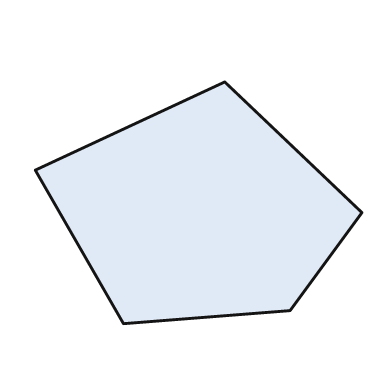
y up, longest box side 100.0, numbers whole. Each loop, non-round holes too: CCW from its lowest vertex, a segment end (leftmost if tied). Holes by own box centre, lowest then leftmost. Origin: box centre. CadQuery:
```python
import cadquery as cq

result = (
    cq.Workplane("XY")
    .moveTo(-23.0, -37.0)
    .lineTo(28.0, -33.0)
    .lineTo(50.0, -3.0)
    .lineTo(8.0, 37.0)
    .lineTo(-50.0, 10.0)
    .close()
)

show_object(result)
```